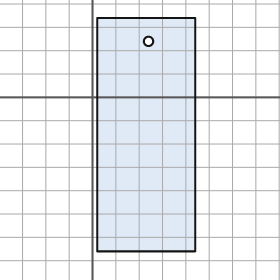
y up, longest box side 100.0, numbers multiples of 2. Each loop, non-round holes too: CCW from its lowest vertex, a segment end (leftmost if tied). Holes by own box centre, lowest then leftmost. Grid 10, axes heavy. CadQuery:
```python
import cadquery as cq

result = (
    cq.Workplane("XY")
    .moveTo(2.0, -66.0)
    .lineTo(44.0, -66.0)
    .lineTo(44.0, 34.0)
    .lineTo(2.0, 34.0)
    .close()
    .moveTo(24.0, 24.0)
    .circle(2.0)
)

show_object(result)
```